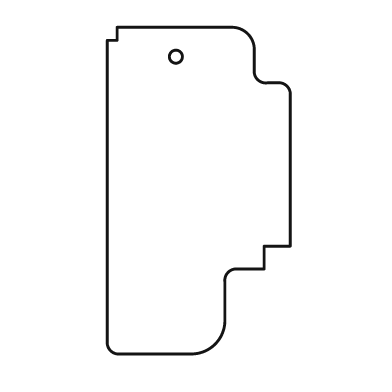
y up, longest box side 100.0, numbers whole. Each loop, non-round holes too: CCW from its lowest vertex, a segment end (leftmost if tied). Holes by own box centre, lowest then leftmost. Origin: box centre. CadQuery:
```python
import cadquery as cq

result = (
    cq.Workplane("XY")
    .moveTo(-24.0, -50.0)
    .lineTo(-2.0, -50.0)
    .threePointArc((5.0, -47.0), (8.0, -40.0))
    .lineTo(8.0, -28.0)
    .threePointArc((9.0, -25.0), (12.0, -24.0))
    .lineTo(20.0, -24.0)
    .lineTo(20.0, -17.0)
    .lineTo(28.0, -17.0)
    .lineTo(28.0, 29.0)
    .threePointArc((27.0, 32.0), (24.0, 33.0))
    .lineTo(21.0, 33.0)
    .threePointArc((18.0, 34.0), (17.0, 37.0))
    .lineTo(17.0, 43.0)
    .threePointArc((15.0, 48.0), (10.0, 50.0))
    .lineTo(-25.0, 50.0)
    .lineTo(-25.0, 46.0)
    .lineTo(-28.0, 46.0)
    .lineTo(-28.0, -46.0)
    .threePointArc((-27.0, -49.0), (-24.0, -50.0))
    .close()
    .moveTo(-7.0, 41.0)
    .circle(2.0)
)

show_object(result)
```